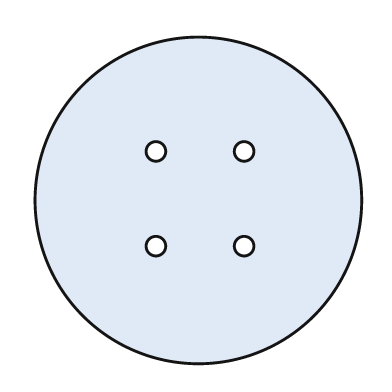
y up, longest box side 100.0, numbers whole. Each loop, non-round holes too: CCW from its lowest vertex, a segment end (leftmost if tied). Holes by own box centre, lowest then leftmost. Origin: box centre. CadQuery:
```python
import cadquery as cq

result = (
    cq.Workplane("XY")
    .moveTo(0.0, 0.0)
    .circle(50.0)
    .moveTo(-13.0, -14.0)
    .circle(3.0)
    .moveTo(14.0, -14.0)
    .circle(3.0)
    .moveTo(-13.0, 15.0)
    .circle(3.0)
    .moveTo(14.0, 15.0)
    .circle(3.0)
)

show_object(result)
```